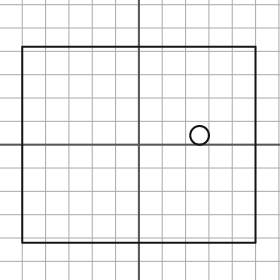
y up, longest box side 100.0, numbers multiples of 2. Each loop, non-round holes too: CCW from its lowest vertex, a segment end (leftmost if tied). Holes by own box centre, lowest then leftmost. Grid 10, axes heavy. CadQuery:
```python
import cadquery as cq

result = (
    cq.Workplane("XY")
    .moveTo(-50.0, -42.0)
    .lineTo(50.0, -42.0)
    .lineTo(50.0, 42.0)
    .lineTo(-50.0, 42.0)
    .close()
    .moveTo(26.0, 4.0)
    .circle(4.0)
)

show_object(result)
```